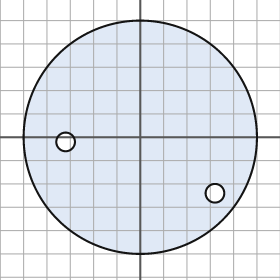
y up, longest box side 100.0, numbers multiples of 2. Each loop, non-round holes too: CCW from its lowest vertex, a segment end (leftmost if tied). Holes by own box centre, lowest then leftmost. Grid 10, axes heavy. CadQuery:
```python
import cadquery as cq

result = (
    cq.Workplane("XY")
    .moveTo(0.0, 0.0)
    .circle(50.0)
    .moveTo(32.0, -24.0)
    .circle(4.0)
    .moveTo(-32.0, -2.0)
    .circle(4.0)
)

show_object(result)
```